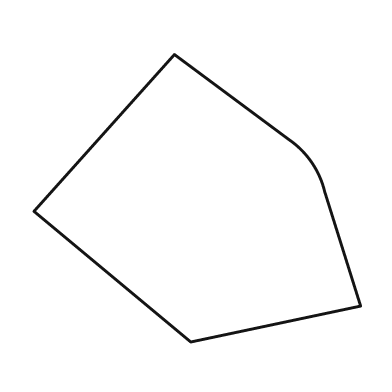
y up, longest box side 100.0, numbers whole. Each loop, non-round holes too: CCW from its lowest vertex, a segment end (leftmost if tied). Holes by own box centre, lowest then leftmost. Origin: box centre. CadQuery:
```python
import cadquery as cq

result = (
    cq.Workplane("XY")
    .moveTo(-2.0, -44.0)
    .lineTo(50.0, -33.0)
    .lineTo(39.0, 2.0)
    .threePointArc((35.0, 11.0), (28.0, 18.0))
    .lineTo(-7.0, 44.0)
    .lineTo(-50.0, -4.0)
    .close()
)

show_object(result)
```